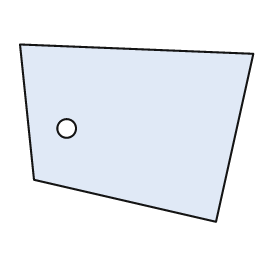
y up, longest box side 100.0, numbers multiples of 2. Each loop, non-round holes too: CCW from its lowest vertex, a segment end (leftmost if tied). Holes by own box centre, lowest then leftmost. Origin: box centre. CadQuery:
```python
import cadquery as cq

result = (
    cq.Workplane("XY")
    .moveTo(34.0, -38.0)
    .lineTo(50.0, 34.0)
    .lineTo(-50.0, 38.0)
    .lineTo(-44.0, -20.0)
    .close()
    .moveTo(-30.0, 2.0)
    .circle(4.0)
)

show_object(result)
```